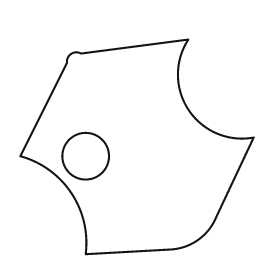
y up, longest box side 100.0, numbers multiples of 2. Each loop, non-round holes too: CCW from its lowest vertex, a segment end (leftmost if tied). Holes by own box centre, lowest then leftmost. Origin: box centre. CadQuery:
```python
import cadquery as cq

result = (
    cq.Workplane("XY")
    .moveTo(-22.0, -46.0)
    .lineTo(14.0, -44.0)
    .threePointArc((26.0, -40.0), (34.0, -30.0))
    .lineTo(50.0, 4.0)
    .threePointArc((22.0, 16.0), (22.0, 46.0))
    .lineTo(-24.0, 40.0)
    .threePointArc((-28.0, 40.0), (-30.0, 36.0))
    .lineTo(-50.0, -4.0)
    .threePointArc((-28.0, -20.0), (-22.0, -46.0))
    .close()
    .moveTo(-22.0, -4.0)
    .circle(10.0)
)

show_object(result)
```